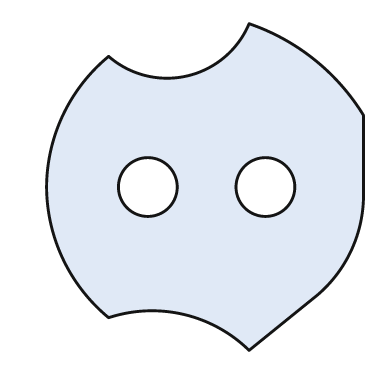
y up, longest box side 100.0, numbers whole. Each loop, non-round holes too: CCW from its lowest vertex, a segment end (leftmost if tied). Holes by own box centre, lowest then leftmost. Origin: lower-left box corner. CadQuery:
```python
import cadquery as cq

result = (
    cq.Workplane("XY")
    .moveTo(62.0, 0.0)
    .lineTo(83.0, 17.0)
    .threePointArc((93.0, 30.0), (97.0, 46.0))
    .lineTo(97.0, 72.0)
    .threePointArc((82.0, 89.0), (62.0, 100.0))
    .threePointArc((43.0, 84.0), (19.0, 90.0))
    .threePointArc((5.0, 72.0), (0.0, 50.0))
    .threePointArc((5.0, 28.0), (19.0, 10.0))
    .threePointArc((42.0, 11.0), (62.0, 0.0))
    .close()
    .moveTo(31.0, 50.0)
    .circle(9.0)
    .moveTo(67.0, 50.0)
    .circle(9.0)
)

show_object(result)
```